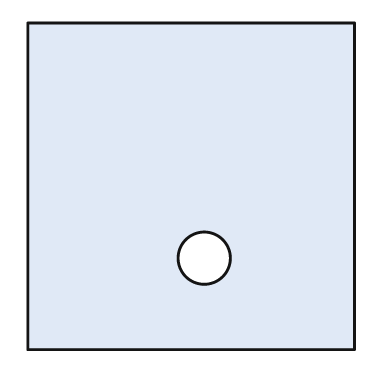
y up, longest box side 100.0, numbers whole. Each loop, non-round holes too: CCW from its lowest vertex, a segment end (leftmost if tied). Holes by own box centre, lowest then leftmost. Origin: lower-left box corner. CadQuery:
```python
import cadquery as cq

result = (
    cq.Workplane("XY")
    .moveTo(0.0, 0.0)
    .lineTo(100.0, 0.0)
    .lineTo(100.0, 100.0)
    .lineTo(0.0, 100.0)
    .close()
    .moveTo(54.0, 28.0)
    .circle(8.0)
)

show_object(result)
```